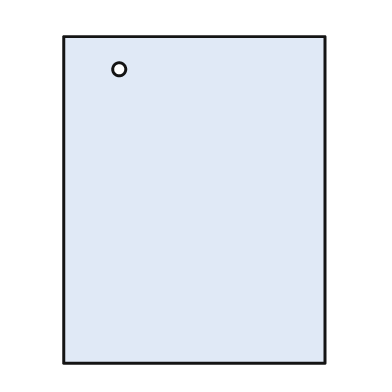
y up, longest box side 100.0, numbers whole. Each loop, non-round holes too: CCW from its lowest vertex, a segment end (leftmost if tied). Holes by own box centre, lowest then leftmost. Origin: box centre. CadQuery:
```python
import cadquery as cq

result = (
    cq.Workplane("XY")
    .moveTo(-40.0, -50.0)
    .lineTo(40.0, -50.0)
    .lineTo(40.0, 50.0)
    .lineTo(-40.0, 50.0)
    .close()
    .moveTo(-23.0, 40.0)
    .circle(2.0)
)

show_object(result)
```